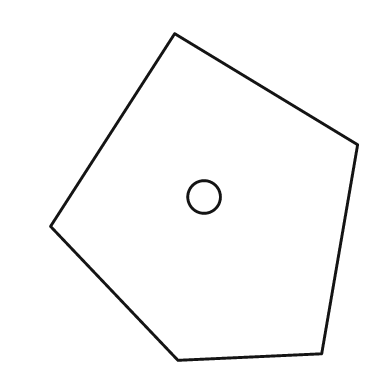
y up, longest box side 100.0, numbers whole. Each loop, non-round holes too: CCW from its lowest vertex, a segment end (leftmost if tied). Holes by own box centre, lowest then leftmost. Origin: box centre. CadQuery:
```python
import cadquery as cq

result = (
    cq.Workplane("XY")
    .moveTo(-8.0, -50.0)
    .lineTo(36.0, -48.0)
    .lineTo(47.0, 16.0)
    .lineTo(-9.0, 50.0)
    .lineTo(-47.0, -9.0)
    .close()
    .moveTo(0.0, 0.0)
    .circle(5.0)
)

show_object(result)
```